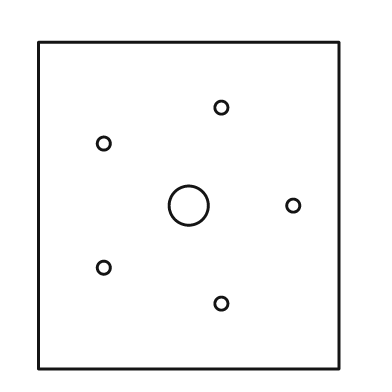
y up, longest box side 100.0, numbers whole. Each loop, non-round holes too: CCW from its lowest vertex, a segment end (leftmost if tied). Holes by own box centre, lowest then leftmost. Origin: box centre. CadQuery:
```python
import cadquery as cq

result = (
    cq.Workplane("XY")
    .moveTo(-46.0, -50.0)
    .lineTo(46.0, -50.0)
    .lineTo(46.0, 50.0)
    .lineTo(-46.0, 50.0)
    .close()
    .moveTo(10.0, -30.0)
    .circle(2.0)
    .moveTo(-26.0, -19.0)
    .circle(2.0)
    .moveTo(0.0, 0.0)
    .circle(6.0)
    .moveTo(32.0, 0.0)
    .circle(2.0)
    .moveTo(-26.0, 19.0)
    .circle(2.0)
    .moveTo(10.0, 30.0)
    .circle(2.0)
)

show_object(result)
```